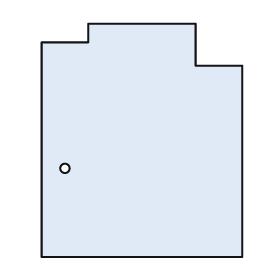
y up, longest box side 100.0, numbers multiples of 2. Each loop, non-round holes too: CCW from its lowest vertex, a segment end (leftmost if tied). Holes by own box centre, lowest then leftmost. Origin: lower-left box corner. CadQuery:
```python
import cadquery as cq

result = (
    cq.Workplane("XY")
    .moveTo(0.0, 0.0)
    .lineTo(86.0, 0.0)
    .lineTo(86.0, 82.0)
    .lineTo(66.0, 82.0)
    .lineTo(66.0, 100.0)
    .lineTo(20.0, 100.0)
    .lineTo(20.0, 92.0)
    .lineTo(0.0, 92.0)
    .close()
    .moveTo(10.0, 38.0)
    .circle(2.0)
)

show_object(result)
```